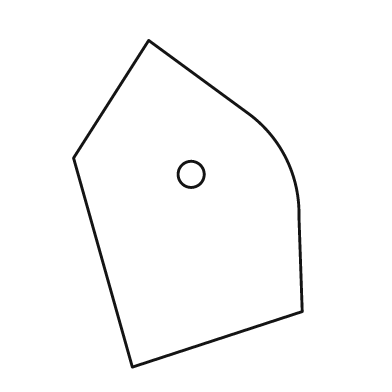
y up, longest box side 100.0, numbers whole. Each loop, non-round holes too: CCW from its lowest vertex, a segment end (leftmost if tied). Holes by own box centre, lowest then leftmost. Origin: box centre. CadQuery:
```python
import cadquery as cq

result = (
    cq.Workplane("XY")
    .moveTo(-17.0, -50.0)
    .lineTo(35.0, -33.0)
    .lineTo(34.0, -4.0)
    .threePointArc((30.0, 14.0), (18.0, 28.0))
    .lineTo(-12.0, 50.0)
    .lineTo(-35.0, 14.0)
    .close()
    .moveTo(1.0, 9.0)
    .circle(4.0)
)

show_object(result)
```